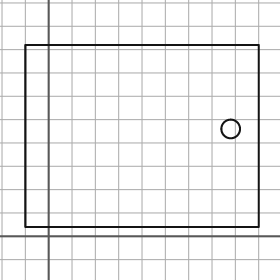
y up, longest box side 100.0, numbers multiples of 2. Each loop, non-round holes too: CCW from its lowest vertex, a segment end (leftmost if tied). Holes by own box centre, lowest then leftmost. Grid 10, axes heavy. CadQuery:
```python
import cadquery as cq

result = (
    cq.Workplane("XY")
    .moveTo(-10.0, 4.0)
    .lineTo(90.0, 4.0)
    .lineTo(90.0, 82.0)
    .lineTo(-10.0, 82.0)
    .close()
    .moveTo(78.0, 46.0)
    .circle(4.0)
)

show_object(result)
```